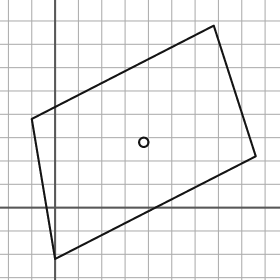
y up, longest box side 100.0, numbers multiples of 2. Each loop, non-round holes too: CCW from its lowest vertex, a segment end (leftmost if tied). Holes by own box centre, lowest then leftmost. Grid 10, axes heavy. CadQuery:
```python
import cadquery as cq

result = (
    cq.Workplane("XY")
    .moveTo(0.0, -22.0)
    .lineTo(86.0, 22.0)
    .lineTo(68.0, 78.0)
    .lineTo(-10.0, 38.0)
    .close()
    .moveTo(38.0, 28.0)
    .circle(2.0)
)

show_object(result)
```